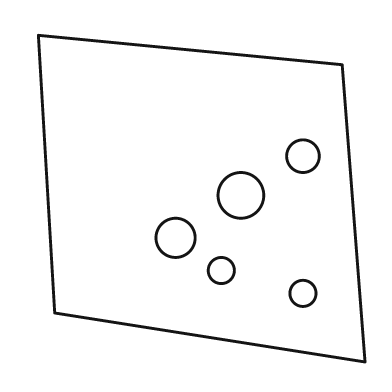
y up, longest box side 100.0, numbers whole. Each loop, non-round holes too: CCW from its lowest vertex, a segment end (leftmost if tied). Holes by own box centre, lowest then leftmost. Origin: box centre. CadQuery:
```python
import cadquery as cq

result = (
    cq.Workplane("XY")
    .moveTo(50.0, -50.0)
    .lineTo(43.0, 41.0)
    .lineTo(-50.0, 50.0)
    .lineTo(-45.0, -35.0)
    .close()
    .moveTo(31.0, -29.0)
    .circle(4.0)
    .moveTo(6.0, -22.0)
    .circle(4.0)
    .moveTo(-8.0, -12.0)
    .circle(6.0)
    .moveTo(12.0, 1.0)
    .circle(7.0)
    .moveTo(31.0, 13.0)
    .circle(5.0)
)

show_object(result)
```